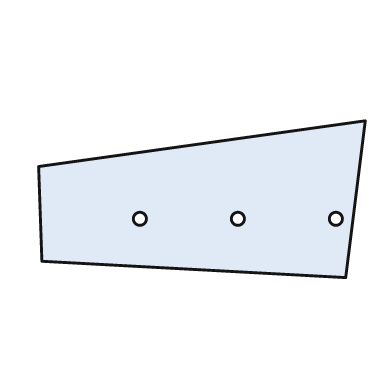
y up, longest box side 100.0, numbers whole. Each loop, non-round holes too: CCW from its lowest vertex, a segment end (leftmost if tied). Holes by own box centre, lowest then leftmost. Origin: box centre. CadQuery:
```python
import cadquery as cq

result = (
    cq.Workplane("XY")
    .moveTo(44.0, -24.0)
    .lineTo(50.0, 24.0)
    .lineTo(-50.0, 10.0)
    .lineTo(-49.0, -19.0)
    .close()
    .moveTo(-19.0, -6.0)
    .circle(2.0)
    .moveTo(11.0, -6.0)
    .circle(2.0)
    .moveTo(41.0, -6.0)
    .circle(2.0)
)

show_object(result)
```